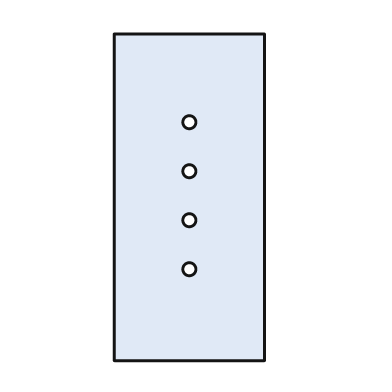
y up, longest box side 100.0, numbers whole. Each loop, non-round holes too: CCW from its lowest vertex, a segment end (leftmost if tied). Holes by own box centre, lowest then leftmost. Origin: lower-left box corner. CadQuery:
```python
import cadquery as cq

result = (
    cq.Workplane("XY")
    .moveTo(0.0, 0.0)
    .lineTo(46.0, 0.0)
    .lineTo(46.0, 100.0)
    .lineTo(0.0, 100.0)
    .close()
    .moveTo(23.0, 28.0)
    .circle(2.0)
    .moveTo(23.0, 43.0)
    .circle(2.0)
    .moveTo(23.0, 58.0)
    .circle(2.0)
    .moveTo(23.0, 73.0)
    .circle(2.0)
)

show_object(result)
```